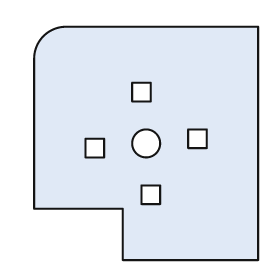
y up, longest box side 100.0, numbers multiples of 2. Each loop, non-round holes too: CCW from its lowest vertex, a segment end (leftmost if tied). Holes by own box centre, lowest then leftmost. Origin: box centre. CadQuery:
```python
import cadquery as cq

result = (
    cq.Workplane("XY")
    .moveTo(-10.0, -50.0)
    .lineTo(48.0, -50.0)
    .lineTo(48.0, 50.0)
    .lineTo(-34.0, 50.0)
    .threePointArc((-44.0, 46.0), (-48.0, 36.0))
    .lineTo(-48.0, -28.0)
    .lineTo(-10.0, -28.0)
    .close()
    .moveTo(-2.0, -26.0)
    .lineTo(6.0, -26.0)
    .lineTo(6.0, -18.0)
    .lineTo(-2.0, -18.0)
    .close()
    .moveTo(-26.0, -6.0)
    .lineTo(-18.0, -6.0)
    .lineTo(-18.0, 2.0)
    .lineTo(-26.0, 2.0)
    .close()
    .moveTo(0.0, 0.0)
    .circle(6.0)
    .moveTo(18.0, -2.0)
    .lineTo(26.0, -2.0)
    .lineTo(26.0, 6.0)
    .lineTo(18.0, 6.0)
    .close()
    .moveTo(-6.0, 18.0)
    .lineTo(2.0, 18.0)
    .lineTo(2.0, 26.0)
    .lineTo(-6.0, 26.0)
    .close()
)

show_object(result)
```